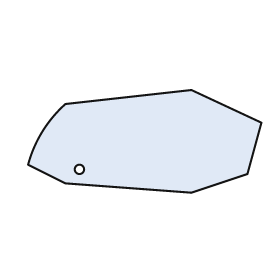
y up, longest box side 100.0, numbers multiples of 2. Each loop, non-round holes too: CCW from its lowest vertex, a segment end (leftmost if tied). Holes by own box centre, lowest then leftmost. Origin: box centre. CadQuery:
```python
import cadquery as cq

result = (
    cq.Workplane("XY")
    .moveTo(20.0, -22.0)
    .lineTo(44.0, -14.0)
    .lineTo(50.0, 8.0)
    .lineTo(20.0, 22.0)
    .lineTo(-34.0, 16.0)
    .threePointArc((-44.0, 4.0), (-50.0, -10.0))
    .lineTo(-34.0, -18.0)
    .close()
    .moveTo(-28.0, -12.0)
    .circle(2.0)
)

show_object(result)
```